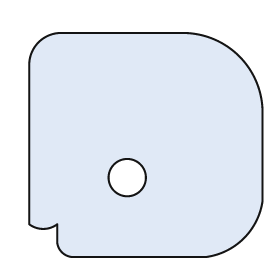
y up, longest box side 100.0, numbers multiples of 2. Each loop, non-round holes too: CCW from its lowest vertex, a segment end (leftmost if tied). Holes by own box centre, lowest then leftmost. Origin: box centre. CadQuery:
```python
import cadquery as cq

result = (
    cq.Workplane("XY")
    .moveTo(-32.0, -48.0)
    .lineTo(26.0, -48.0)
    .threePointArc((42.0, -40.0), (50.0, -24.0))
    .lineTo(50.0, 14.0)
    .threePointArc((40.0, 38.0), (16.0, 48.0))
    .lineTo(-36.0, 48.0)
    .threePointArc((-46.0, 44.0), (-50.0, 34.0))
    .lineTo(-50.0, -34.0)
    .threePointArc((-44.0, -36.0), (-38.0, -34.0))
    .lineTo(-38.0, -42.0)
    .threePointArc((-36.0, -46.0), (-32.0, -48.0))
    .close()
    .moveTo(-8.0, -14.0)
    .circle(8.0)
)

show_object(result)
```